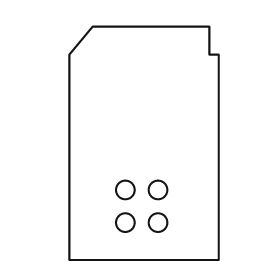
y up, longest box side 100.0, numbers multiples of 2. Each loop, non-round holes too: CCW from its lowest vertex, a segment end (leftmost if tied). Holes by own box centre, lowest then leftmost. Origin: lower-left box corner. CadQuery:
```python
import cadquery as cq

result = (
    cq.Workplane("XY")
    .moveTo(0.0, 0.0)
    .lineTo(64.0, 0.0)
    .lineTo(64.0, 88.0)
    .lineTo(60.0, 88.0)
    .lineTo(60.0, 100.0)
    .lineTo(10.0, 100.0)
    .lineTo(0.0, 88.0)
    .close()
    .moveTo(24.0, 16.0)
    .circle(4.0)
    .moveTo(38.0, 16.0)
    .circle(4.0)
    .moveTo(24.0, 30.0)
    .circle(4.0)
    .moveTo(38.0, 30.0)
    .circle(4.0)
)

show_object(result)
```